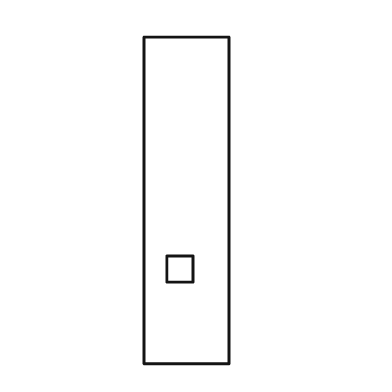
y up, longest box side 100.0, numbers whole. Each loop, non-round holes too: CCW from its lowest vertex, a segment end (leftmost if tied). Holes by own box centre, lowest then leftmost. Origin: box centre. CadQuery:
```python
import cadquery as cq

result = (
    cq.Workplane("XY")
    .moveTo(-13.0, -50.0)
    .lineTo(13.0, -50.0)
    .lineTo(13.0, 50.0)
    .lineTo(-13.0, 50.0)
    .close()
    .moveTo(-6.0, -25.0)
    .lineTo(2.0, -25.0)
    .lineTo(2.0, -17.0)
    .lineTo(-6.0, -17.0)
    .close()
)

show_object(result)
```